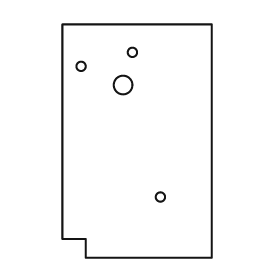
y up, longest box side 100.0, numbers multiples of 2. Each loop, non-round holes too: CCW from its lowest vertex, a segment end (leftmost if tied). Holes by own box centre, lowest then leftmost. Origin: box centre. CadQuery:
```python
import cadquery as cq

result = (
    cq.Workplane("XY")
    .moveTo(-22.0, -50.0)
    .lineTo(32.0, -50.0)
    .lineTo(32.0, 50.0)
    .lineTo(-32.0, 50.0)
    .lineTo(-32.0, -42.0)
    .lineTo(-22.0, -42.0)
    .close()
    .moveTo(10.0, -24.0)
    .circle(2.0)
    .moveTo(-6.0, 24.0)
    .circle(4.0)
    .moveTo(-24.0, 32.0)
    .circle(2.0)
    .moveTo(-2.0, 38.0)
    .circle(2.0)
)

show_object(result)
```